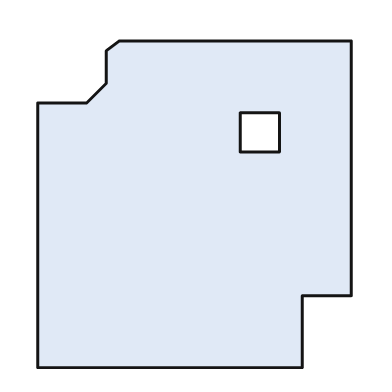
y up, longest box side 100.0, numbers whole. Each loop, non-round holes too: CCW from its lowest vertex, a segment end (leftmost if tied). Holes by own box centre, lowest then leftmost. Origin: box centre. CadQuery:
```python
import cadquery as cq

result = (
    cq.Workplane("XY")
    .moveTo(-48.0, -50.0)
    .lineTo(33.0, -50.0)
    .lineTo(33.0, -28.0)
    .lineTo(48.0, -28.0)
    .lineTo(48.0, 50.0)
    .lineTo(-23.0, 50.0)
    .lineTo(-27.0, 47.0)
    .lineTo(-27.0, 37.0)
    .lineTo(-33.0, 31.0)
    .lineTo(-48.0, 31.0)
    .close()
    .moveTo(14.0, 16.0)
    .lineTo(26.0, 16.0)
    .lineTo(26.0, 28.0)
    .lineTo(14.0, 28.0)
    .close()
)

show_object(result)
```